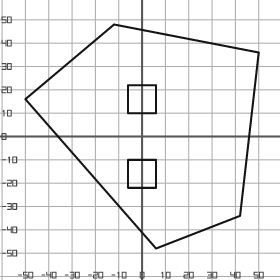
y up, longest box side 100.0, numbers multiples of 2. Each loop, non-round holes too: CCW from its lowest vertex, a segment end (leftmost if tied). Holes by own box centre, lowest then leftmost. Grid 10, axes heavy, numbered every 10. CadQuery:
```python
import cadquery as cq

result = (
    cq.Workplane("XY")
    .moveTo(6.0, -48.0)
    .lineTo(42.0, -34.0)
    .lineTo(50.0, 36.0)
    .lineTo(-12.0, 48.0)
    .lineTo(-50.0, 16.0)
    .close()
    .moveTo(-6.0, -22.0)
    .lineTo(6.0, -22.0)
    .lineTo(6.0, -10.0)
    .lineTo(-6.0, -10.0)
    .close()
    .moveTo(-6.0, 10.0)
    .lineTo(6.0, 10.0)
    .lineTo(6.0, 22.0)
    .lineTo(-6.0, 22.0)
    .close()
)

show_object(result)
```